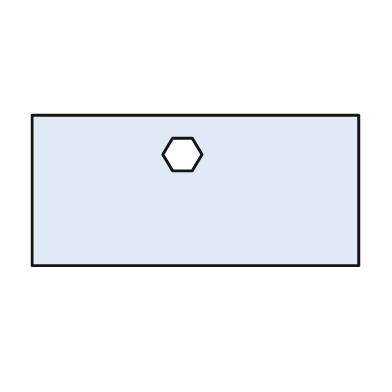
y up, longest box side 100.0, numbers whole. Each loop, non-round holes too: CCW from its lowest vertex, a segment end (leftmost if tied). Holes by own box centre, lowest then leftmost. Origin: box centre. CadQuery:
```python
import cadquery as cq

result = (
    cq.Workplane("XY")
    .moveTo(-50.0, -23.0)
    .lineTo(50.0, -23.0)
    .lineTo(50.0, 23.0)
    .lineTo(-50.0, 23.0)
    .close()
    .moveTo(-7.0, 6.0)
    .lineTo(-1.0, 6.0)
    .lineTo(2.0, 11.0)
    .lineTo(-1.0, 16.0)
    .lineTo(-7.0, 16.0)
    .lineTo(-10.0, 11.0)
    .close()
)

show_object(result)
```